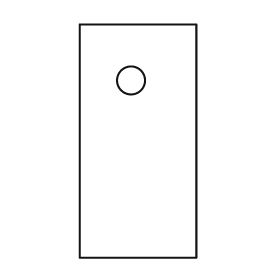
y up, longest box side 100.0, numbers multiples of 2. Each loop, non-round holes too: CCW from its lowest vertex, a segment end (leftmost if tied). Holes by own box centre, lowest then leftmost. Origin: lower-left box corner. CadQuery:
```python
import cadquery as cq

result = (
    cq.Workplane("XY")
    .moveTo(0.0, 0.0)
    .lineTo(50.0, 0.0)
    .lineTo(50.0, 100.0)
    .lineTo(0.0, 100.0)
    .close()
    .moveTo(22.0, 76.0)
    .circle(6.0)
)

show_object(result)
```